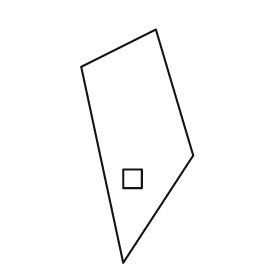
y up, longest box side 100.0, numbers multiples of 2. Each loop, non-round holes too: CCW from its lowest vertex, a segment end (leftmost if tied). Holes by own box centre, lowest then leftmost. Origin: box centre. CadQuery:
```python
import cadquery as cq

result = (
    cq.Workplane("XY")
    .moveTo(-6.0, -50.0)
    .lineTo(24.0, -4.0)
    .lineTo(8.0, 50.0)
    .lineTo(-24.0, 34.0)
    .close()
    .moveTo(-6.0, -18.0)
    .lineTo(2.0, -18.0)
    .lineTo(2.0, -10.0)
    .lineTo(-6.0, -10.0)
    .close()
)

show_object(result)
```